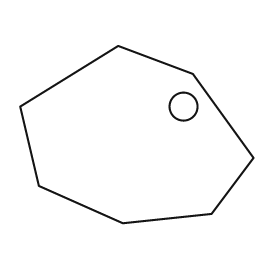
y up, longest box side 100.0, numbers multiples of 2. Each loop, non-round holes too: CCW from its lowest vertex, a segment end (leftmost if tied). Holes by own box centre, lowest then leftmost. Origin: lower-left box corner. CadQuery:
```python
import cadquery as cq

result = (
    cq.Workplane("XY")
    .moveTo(44.0, 0.0)
    .lineTo(82.0, 4.0)
    .lineTo(100.0, 28.0)
    .lineTo(74.0, 64.0)
    .lineTo(42.0, 76.0)
    .lineTo(0.0, 50.0)
    .lineTo(8.0, 16.0)
    .close()
    .moveTo(70.0, 50.0)
    .circle(6.0)
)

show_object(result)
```